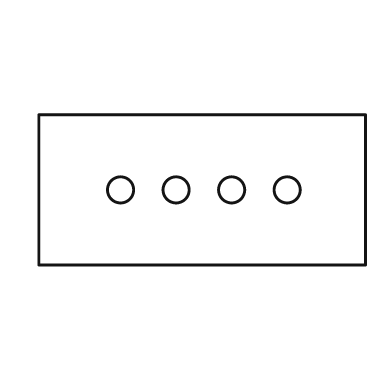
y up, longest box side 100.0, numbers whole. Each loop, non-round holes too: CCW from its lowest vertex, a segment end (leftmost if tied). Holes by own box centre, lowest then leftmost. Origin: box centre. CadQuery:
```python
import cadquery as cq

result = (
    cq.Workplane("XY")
    .moveTo(-50.0, -23.0)
    .lineTo(50.0, -23.0)
    .lineTo(50.0, 23.0)
    .lineTo(-50.0, 23.0)
    .close()
    .moveTo(-25.0, 0.0)
    .circle(4.0)
    .moveTo(-8.0, 0.0)
    .circle(4.0)
    .moveTo(9.0, 0.0)
    .circle(4.0)
    .moveTo(26.0, 0.0)
    .circle(4.0)
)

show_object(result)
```